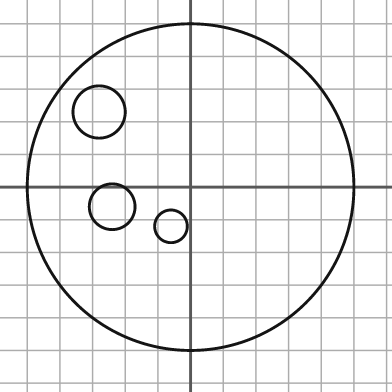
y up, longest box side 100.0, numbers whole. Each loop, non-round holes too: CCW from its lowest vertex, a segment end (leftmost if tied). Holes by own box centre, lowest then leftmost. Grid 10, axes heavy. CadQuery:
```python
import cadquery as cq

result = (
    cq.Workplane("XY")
    .moveTo(0.0, 0.0)
    .circle(50.0)
    .moveTo(-6.0, -12.0)
    .circle(5.0)
    .moveTo(-24.0, -6.0)
    .circle(7.0)
    .moveTo(-28.0, 23.0)
    .circle(8.0)
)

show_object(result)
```